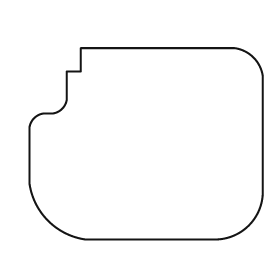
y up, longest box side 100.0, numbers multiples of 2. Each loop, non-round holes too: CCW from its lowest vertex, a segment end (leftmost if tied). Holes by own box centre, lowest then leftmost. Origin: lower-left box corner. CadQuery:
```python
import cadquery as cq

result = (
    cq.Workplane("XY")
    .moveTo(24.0, 0.0)
    .lineTo(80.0, 0.0)
    .threePointArc((94.0, 6.0), (100.0, 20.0))
    .lineTo(100.0, 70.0)
    .threePointArc((96.0, 78.0), (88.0, 82.0))
    .lineTo(22.0, 82.0)
    .lineTo(22.0, 72.0)
    .lineTo(16.0, 72.0)
    .lineTo(16.0, 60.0)
    .threePointArc((14.0, 56.0), (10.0, 54.0))
    .lineTo(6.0, 54.0)
    .threePointArc((2.0, 52.0), (0.0, 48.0))
    .lineTo(0.0, 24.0)
    .threePointArc((8.0, 8.0), (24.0, 0.0))
    .close()
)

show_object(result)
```